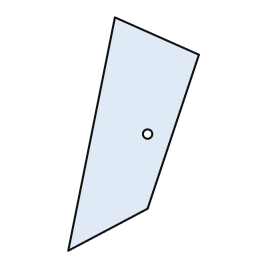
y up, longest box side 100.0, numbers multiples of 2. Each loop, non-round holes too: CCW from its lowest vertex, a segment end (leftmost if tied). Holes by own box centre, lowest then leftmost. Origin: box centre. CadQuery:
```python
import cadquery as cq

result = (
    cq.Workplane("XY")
    .moveTo(-28.0, -50.0)
    .lineTo(6.0, -32.0)
    .lineTo(28.0, 34.0)
    .lineTo(-8.0, 50.0)
    .close()
    .moveTo(6.0, 0.0)
    .circle(2.0)
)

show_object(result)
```